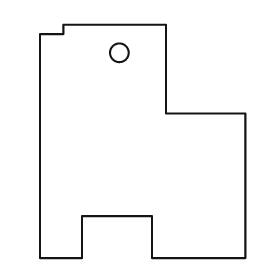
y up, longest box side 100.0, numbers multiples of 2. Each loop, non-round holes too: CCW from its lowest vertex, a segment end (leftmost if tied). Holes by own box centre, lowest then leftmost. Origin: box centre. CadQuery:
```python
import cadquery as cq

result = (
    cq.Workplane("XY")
    .moveTo(-44.0, -50.0)
    .lineTo(-26.0, -50.0)
    .lineTo(-26.0, -32.0)
    .lineTo(4.0, -32.0)
    .lineTo(4.0, -50.0)
    .lineTo(44.0, -50.0)
    .lineTo(44.0, 12.0)
    .lineTo(10.0, 12.0)
    .lineTo(10.0, 50.0)
    .lineTo(-34.0, 50.0)
    .lineTo(-34.0, 46.0)
    .lineTo(-44.0, 46.0)
    .close()
    .moveTo(-10.0, 38.0)
    .circle(4.0)
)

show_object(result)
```